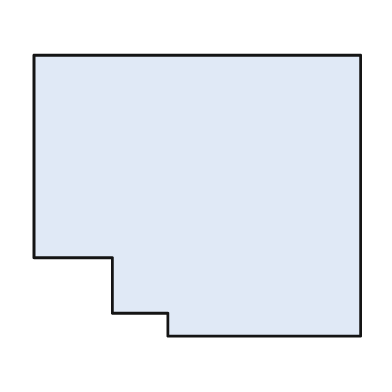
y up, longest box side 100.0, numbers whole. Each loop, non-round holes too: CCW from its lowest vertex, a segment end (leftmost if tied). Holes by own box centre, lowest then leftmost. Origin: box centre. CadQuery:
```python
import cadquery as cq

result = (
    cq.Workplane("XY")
    .moveTo(-9.0, -43.0)
    .lineTo(50.0, -43.0)
    .lineTo(50.0, 43.0)
    .lineTo(-50.0, 43.0)
    .lineTo(-50.0, -19.0)
    .lineTo(-26.0, -19.0)
    .lineTo(-26.0, -36.0)
    .lineTo(-9.0, -36.0)
    .close()
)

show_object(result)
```